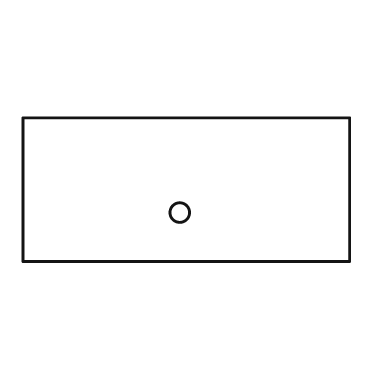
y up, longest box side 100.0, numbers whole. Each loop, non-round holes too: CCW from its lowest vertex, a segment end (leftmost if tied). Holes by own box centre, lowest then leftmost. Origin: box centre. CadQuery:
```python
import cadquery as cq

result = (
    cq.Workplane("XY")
    .moveTo(-50.0, -22.0)
    .lineTo(50.0, -22.0)
    .lineTo(50.0, 22.0)
    .lineTo(-50.0, 22.0)
    .close()
    .moveTo(-2.0, -7.0)
    .circle(3.0)
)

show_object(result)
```